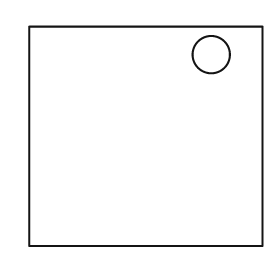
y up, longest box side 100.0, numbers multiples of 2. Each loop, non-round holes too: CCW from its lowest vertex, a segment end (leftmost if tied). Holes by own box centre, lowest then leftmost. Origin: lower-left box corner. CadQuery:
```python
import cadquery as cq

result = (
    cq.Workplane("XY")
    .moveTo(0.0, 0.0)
    .lineTo(100.0, 0.0)
    .lineTo(100.0, 94.0)
    .lineTo(0.0, 94.0)
    .close()
    .moveTo(78.0, 82.0)
    .circle(8.0)
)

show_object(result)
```